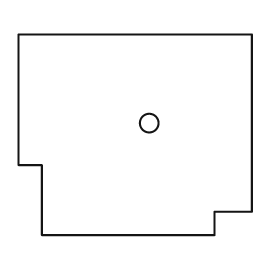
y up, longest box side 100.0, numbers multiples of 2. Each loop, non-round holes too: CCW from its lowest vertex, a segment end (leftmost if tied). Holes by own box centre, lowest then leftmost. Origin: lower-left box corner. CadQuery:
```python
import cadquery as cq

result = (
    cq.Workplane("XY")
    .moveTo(10.0, 0.0)
    .lineTo(84.0, 0.0)
    .lineTo(84.0, 10.0)
    .lineTo(100.0, 10.0)
    .lineTo(100.0, 86.0)
    .lineTo(0.0, 86.0)
    .lineTo(0.0, 30.0)
    .lineTo(10.0, 30.0)
    .close()
    .moveTo(56.0, 48.0)
    .circle(4.0)
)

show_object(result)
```